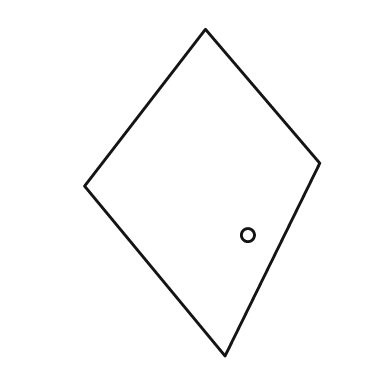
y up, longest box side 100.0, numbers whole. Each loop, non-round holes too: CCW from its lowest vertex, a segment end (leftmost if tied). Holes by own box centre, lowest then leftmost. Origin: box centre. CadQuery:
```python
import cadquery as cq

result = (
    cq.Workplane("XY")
    .moveTo(7.0, -50.0)
    .lineTo(36.0, 9.0)
    .lineTo(1.0, 50.0)
    .lineTo(-36.0, 2.0)
    .close()
    .moveTo(14.0, -13.0)
    .circle(2.0)
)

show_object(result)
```